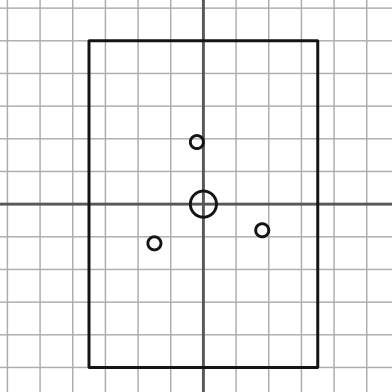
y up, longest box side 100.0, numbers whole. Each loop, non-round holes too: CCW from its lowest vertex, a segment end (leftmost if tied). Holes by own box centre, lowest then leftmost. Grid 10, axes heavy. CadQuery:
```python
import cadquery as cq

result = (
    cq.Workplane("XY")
    .moveTo(-35.0, -50.0)
    .lineTo(35.0, -50.0)
    .lineTo(35.0, 50.0)
    .lineTo(-35.0, 50.0)
    .close()
    .moveTo(-15.0, -12.0)
    .circle(2.0)
    .moveTo(18.0, -8.0)
    .circle(2.0)
    .moveTo(0.0, 0.0)
    .circle(4.0)
    .moveTo(-2.0, 19.0)
    .circle(2.0)
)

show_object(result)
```